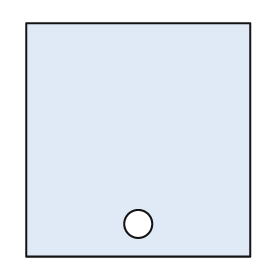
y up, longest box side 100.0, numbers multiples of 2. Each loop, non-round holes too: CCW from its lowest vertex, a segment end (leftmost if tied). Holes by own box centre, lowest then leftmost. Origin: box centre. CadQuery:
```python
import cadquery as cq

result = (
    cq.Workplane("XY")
    .moveTo(-48.0, -50.0)
    .lineTo(48.0, -50.0)
    .lineTo(48.0, 50.0)
    .lineTo(-48.0, 50.0)
    .close()
    .moveTo(0.0, -36.0)
    .circle(6.0)
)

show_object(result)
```